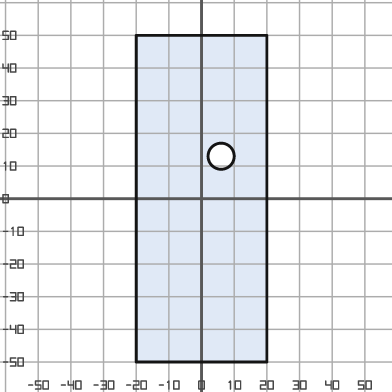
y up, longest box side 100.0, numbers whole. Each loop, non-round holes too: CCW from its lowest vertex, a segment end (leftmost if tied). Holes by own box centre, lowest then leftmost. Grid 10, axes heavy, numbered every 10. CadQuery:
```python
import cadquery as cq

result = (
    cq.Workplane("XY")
    .moveTo(-20.0, -50.0)
    .lineTo(20.0, -50.0)
    .lineTo(20.0, 50.0)
    .lineTo(-20.0, 50.0)
    .close()
    .moveTo(6.0, 13.0)
    .circle(4.0)
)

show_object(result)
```